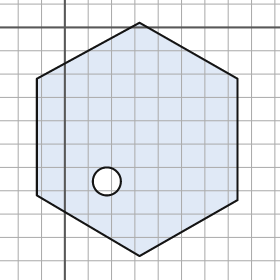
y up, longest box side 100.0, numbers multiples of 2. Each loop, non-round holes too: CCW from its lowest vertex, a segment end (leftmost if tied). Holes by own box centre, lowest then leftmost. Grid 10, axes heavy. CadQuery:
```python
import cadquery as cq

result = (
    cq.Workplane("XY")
    .moveTo(32.0, -98.0)
    .lineTo(74.0, -74.0)
    .lineTo(74.0, -22.0)
    .lineTo(32.0, 2.0)
    .lineTo(-12.0, -22.0)
    .lineTo(-12.0, -72.0)
    .close()
    .moveTo(18.0, -66.0)
    .circle(6.0)
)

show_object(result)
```